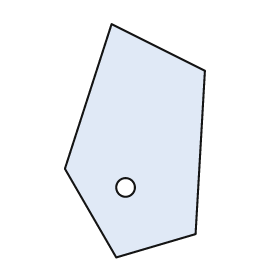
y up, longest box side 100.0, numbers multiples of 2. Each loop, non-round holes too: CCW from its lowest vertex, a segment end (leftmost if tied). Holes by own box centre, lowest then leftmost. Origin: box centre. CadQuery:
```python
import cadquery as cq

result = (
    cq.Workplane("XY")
    .moveTo(-8.0, -50.0)
    .lineTo(26.0, -40.0)
    .lineTo(30.0, 30.0)
    .lineTo(-10.0, 50.0)
    .lineTo(-30.0, -12.0)
    .close()
    .moveTo(-4.0, -20.0)
    .circle(4.0)
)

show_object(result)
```